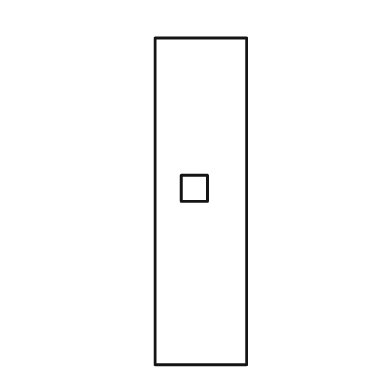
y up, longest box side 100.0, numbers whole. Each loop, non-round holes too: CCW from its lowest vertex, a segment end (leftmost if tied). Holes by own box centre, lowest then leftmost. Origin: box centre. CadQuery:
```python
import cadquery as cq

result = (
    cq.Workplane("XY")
    .moveTo(-14.0, -50.0)
    .lineTo(14.0, -50.0)
    .lineTo(14.0, 50.0)
    .lineTo(-14.0, 50.0)
    .close()
    .moveTo(-6.0, 0.0)
    .lineTo(2.0, 0.0)
    .lineTo(2.0, 8.0)
    .lineTo(-6.0, 8.0)
    .close()
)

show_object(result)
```